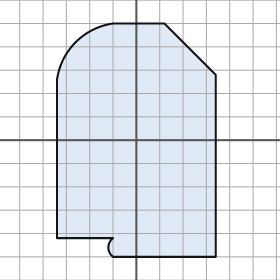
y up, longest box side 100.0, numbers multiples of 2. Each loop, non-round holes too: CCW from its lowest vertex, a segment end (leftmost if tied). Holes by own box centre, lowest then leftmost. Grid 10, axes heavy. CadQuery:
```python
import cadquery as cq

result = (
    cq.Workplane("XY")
    .moveTo(-10.0, -50.0)
    .lineTo(34.0, -50.0)
    .lineTo(34.0, 28.0)
    .lineTo(12.0, 50.0)
    .lineTo(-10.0, 50.0)
    .threePointArc((-26.0, 42.0), (-34.0, 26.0))
    .lineTo(-34.0, -42.0)
    .lineTo(-10.0, -42.0)
    .threePointArc((-12.0, -46.0), (-10.0, -50.0))
    .close()
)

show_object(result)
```